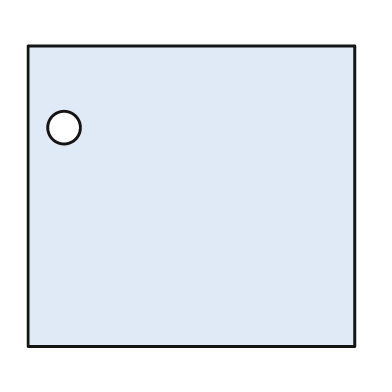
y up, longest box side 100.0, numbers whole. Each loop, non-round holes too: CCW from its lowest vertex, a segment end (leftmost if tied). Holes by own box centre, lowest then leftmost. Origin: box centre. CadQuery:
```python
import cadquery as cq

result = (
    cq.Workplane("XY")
    .moveTo(-50.0, -46.0)
    .lineTo(50.0, -46.0)
    .lineTo(50.0, 46.0)
    .lineTo(-50.0, 46.0)
    .close()
    .moveTo(-39.0, 21.0)
    .circle(5.0)
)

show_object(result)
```